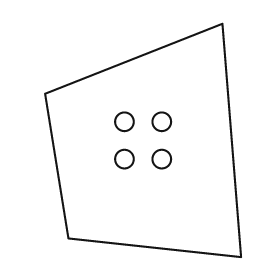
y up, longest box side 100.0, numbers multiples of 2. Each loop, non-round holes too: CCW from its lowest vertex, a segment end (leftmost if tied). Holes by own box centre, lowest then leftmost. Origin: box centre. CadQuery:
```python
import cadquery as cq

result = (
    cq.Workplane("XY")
    .moveTo(42.0, -50.0)
    .lineTo(34.0, 50.0)
    .lineTo(-42.0, 20.0)
    .lineTo(-32.0, -42.0)
    .close()
    .moveTo(-8.0, -8.0)
    .circle(4.0)
    .moveTo(8.0, -8.0)
    .circle(4.0)
    .moveTo(-8.0, 8.0)
    .circle(4.0)
    .moveTo(8.0, 8.0)
    .circle(4.0)
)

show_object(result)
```